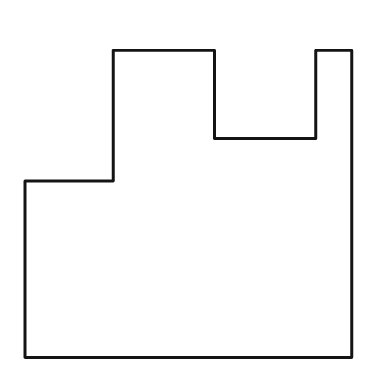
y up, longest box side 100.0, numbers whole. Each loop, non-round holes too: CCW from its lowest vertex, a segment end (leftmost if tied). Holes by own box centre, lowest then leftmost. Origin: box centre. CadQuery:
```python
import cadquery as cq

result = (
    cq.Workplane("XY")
    .moveTo(-50.0, -47.0)
    .lineTo(50.0, -47.0)
    .lineTo(50.0, 47.0)
    .lineTo(39.0, 47.0)
    .lineTo(39.0, 20.0)
    .lineTo(8.0, 20.0)
    .lineTo(8.0, 47.0)
    .lineTo(-23.0, 47.0)
    .lineTo(-23.0, 7.0)
    .lineTo(-50.0, 7.0)
    .close()
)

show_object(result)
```